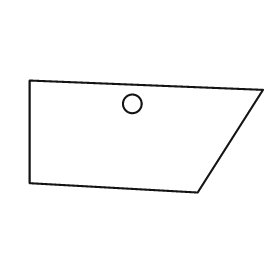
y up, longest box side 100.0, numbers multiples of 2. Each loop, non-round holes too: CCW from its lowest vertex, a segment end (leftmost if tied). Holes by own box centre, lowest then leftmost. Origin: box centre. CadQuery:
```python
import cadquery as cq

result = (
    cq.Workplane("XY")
    .moveTo(22.0, -24.0)
    .lineTo(50.0, 20.0)
    .lineTo(-50.0, 24.0)
    .lineTo(-50.0, -20.0)
    .close()
    .moveTo(-6.0, 14.0)
    .circle(4.0)
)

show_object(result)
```